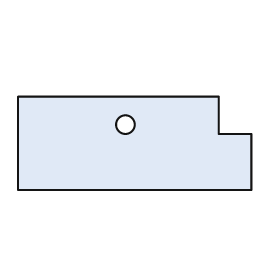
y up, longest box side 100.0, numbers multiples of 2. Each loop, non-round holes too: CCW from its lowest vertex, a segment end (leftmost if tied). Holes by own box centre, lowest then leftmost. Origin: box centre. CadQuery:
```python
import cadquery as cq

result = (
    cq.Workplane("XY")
    .moveTo(-50.0, -20.0)
    .lineTo(50.0, -20.0)
    .lineTo(50.0, 4.0)
    .lineTo(36.0, 4.0)
    .lineTo(36.0, 20.0)
    .lineTo(-50.0, 20.0)
    .close()
    .moveTo(-4.0, 8.0)
    .circle(4.0)
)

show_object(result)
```